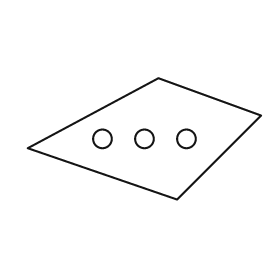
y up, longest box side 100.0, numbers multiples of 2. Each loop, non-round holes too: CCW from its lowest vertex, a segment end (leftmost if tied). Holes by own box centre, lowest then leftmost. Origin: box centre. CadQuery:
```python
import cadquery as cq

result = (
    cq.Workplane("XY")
    .moveTo(14.0, -26.0)
    .lineTo(50.0, 10.0)
    .lineTo(6.0, 26.0)
    .lineTo(-50.0, -4.0)
    .close()
    .moveTo(-18.0, 0.0)
    .circle(4.0)
    .moveTo(0.0, 0.0)
    .circle(4.0)
    .moveTo(18.0, 0.0)
    .circle(4.0)
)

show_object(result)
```